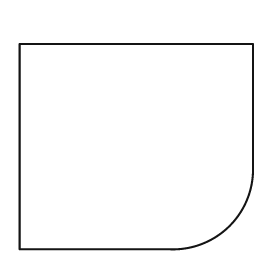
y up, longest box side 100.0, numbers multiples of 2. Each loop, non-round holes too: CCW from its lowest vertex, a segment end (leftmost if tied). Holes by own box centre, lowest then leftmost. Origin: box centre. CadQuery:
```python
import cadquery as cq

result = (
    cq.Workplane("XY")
    .moveTo(-50.0, -44.0)
    .lineTo(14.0, -44.0)
    .threePointArc((40.0, -34.0), (50.0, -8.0))
    .lineTo(50.0, 44.0)
    .lineTo(-50.0, 44.0)
    .close()
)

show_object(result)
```